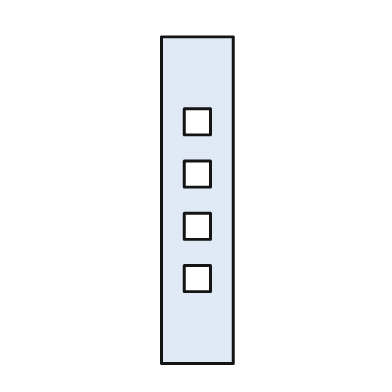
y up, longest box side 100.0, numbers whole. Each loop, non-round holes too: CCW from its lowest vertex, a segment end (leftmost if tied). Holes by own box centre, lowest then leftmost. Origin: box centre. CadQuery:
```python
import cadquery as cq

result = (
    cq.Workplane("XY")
    .moveTo(-11.0, -50.0)
    .lineTo(11.0, -50.0)
    .lineTo(11.0, 50.0)
    .lineTo(-11.0, 50.0)
    .close()
    .moveTo(-4.0, -28.0)
    .lineTo(4.0, -28.0)
    .lineTo(4.0, -20.0)
    .lineTo(-4.0, -20.0)
    .close()
    .moveTo(-4.0, -12.0)
    .lineTo(4.0, -12.0)
    .lineTo(4.0, -4.0)
    .lineTo(-4.0, -4.0)
    .close()
    .moveTo(-4.0, 4.0)
    .lineTo(4.0, 4.0)
    .lineTo(4.0, 12.0)
    .lineTo(-4.0, 12.0)
    .close()
    .moveTo(-4.0, 20.0)
    .lineTo(4.0, 20.0)
    .lineTo(4.0, 28.0)
    .lineTo(-4.0, 28.0)
    .close()
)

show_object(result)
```